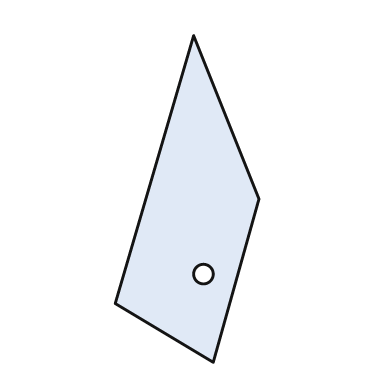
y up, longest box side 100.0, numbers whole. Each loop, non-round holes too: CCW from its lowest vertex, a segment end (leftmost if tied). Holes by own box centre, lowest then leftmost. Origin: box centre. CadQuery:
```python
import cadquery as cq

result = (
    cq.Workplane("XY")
    .moveTo(8.0, -50.0)
    .lineTo(22.0, 0.0)
    .lineTo(2.0, 50.0)
    .lineTo(-22.0, -32.0)
    .close()
    .moveTo(5.0, -23.0)
    .circle(3.0)
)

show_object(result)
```